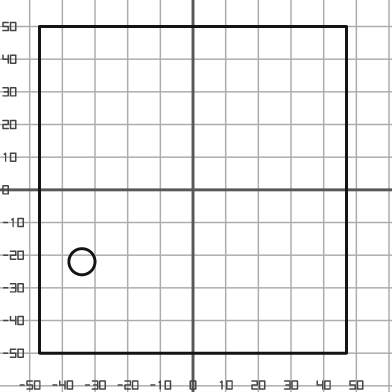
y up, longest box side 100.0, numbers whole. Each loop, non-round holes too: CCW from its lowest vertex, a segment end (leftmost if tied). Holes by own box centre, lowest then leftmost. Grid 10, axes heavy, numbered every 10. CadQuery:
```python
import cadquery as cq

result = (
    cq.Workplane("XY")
    .moveTo(-47.0, -50.0)
    .lineTo(47.0, -50.0)
    .lineTo(47.0, 50.0)
    .lineTo(-47.0, 50.0)
    .close()
    .moveTo(-34.0, -22.0)
    .circle(4.0)
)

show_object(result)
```